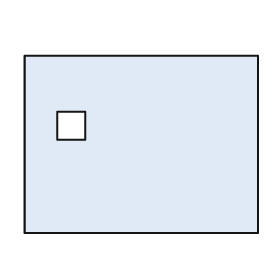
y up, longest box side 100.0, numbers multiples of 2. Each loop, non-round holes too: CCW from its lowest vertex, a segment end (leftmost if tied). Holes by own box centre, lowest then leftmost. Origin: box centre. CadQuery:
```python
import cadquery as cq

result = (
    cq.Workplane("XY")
    .moveTo(-50.0, -38.0)
    .lineTo(50.0, -38.0)
    .lineTo(50.0, 38.0)
    .lineTo(-50.0, 38.0)
    .close()
    .moveTo(-36.0, 2.0)
    .lineTo(-24.0, 2.0)
    .lineTo(-24.0, 14.0)
    .lineTo(-36.0, 14.0)
    .close()
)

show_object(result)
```